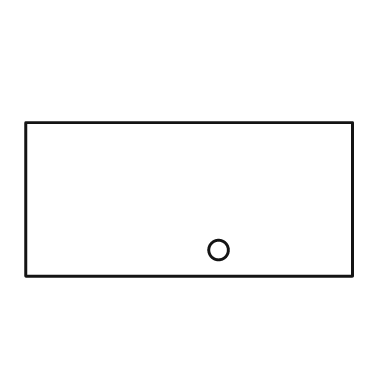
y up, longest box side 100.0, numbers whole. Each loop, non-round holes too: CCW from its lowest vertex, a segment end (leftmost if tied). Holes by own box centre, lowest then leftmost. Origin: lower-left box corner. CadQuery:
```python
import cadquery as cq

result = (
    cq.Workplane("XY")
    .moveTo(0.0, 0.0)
    .lineTo(100.0, 0.0)
    .lineTo(100.0, 47.0)
    .lineTo(0.0, 47.0)
    .close()
    .moveTo(59.0, 8.0)
    .circle(3.0)
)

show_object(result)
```